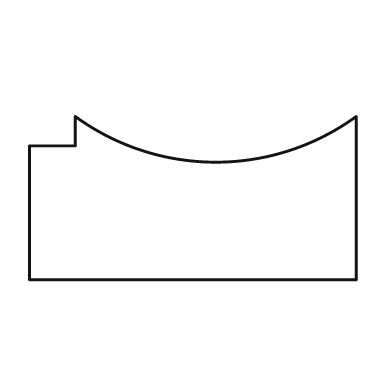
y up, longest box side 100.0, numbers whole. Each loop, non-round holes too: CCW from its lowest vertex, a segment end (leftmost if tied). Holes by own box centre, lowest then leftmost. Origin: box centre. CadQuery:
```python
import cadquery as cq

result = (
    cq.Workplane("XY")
    .moveTo(-50.0, -25.0)
    .lineTo(50.0, -25.0)
    .lineTo(50.0, 25.0)
    .threePointArc((7.0, 11.0), (-36.0, 25.0))
    .lineTo(-36.0, 16.0)
    .lineTo(-50.0, 16.0)
    .close()
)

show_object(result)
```